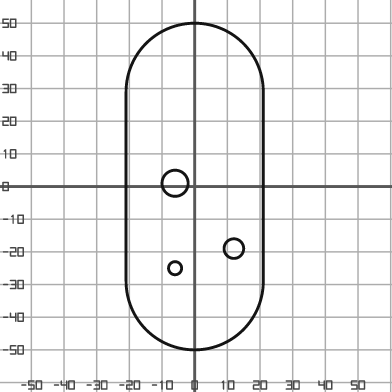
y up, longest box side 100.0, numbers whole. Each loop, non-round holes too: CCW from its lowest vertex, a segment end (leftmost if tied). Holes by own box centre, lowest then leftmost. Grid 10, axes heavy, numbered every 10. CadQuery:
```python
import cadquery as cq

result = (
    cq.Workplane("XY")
    .moveTo(-21.0, -29.0)
    .threePointArc((0.0, -50.0), (21.0, -29.0))
    .lineTo(21.0, 29.0)
    .threePointArc((0.0, 50.0), (-21.0, 29.0))
    .close()
    .moveTo(-6.0, -25.0)
    .circle(2.0)
    .moveTo(12.0, -19.0)
    .circle(3.0)
    .moveTo(-6.0, 1.0)
    .circle(4.0)
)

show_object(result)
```